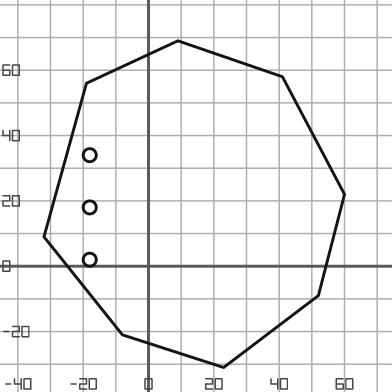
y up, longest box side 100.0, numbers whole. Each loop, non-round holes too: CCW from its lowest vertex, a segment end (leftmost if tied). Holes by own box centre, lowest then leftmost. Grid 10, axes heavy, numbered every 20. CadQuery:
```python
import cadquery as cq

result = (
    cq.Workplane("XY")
    .moveTo(23.0, -31.0)
    .lineTo(52.0, -9.0)
    .lineTo(60.0, 22.0)
    .lineTo(41.0, 58.0)
    .lineTo(9.0, 69.0)
    .lineTo(-19.0, 56.0)
    .lineTo(-32.0, 9.0)
    .lineTo(-8.0, -21.0)
    .close()
    .moveTo(-18.0, 2.0)
    .circle(2.0)
    .moveTo(-18.0, 18.0)
    .circle(2.0)
    .moveTo(-18.0, 34.0)
    .circle(2.0)
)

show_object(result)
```